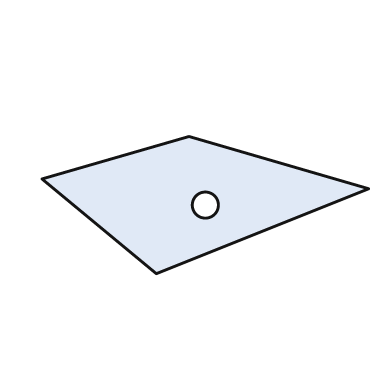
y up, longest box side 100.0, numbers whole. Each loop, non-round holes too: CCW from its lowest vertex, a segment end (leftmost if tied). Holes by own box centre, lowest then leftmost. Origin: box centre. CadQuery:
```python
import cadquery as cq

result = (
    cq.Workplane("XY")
    .moveTo(-15.0, -21.0)
    .lineTo(50.0, 5.0)
    .lineTo(-5.0, 21.0)
    .lineTo(-50.0, 8.0)
    .close()
    .moveTo(0.0, 0.0)
    .circle(4.0)
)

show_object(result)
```